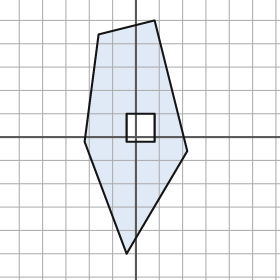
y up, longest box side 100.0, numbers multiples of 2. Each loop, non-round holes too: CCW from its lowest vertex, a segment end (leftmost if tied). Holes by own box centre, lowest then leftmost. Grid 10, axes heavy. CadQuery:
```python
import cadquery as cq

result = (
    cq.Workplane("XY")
    .moveTo(-4.0, -50.0)
    .lineTo(22.0, -6.0)
    .lineTo(8.0, 50.0)
    .lineTo(-16.0, 44.0)
    .lineTo(-22.0, -2.0)
    .close()
    .moveTo(-4.0, -2.0)
    .lineTo(8.0, -2.0)
    .lineTo(8.0, 10.0)
    .lineTo(-4.0, 10.0)
    .close()
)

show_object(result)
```